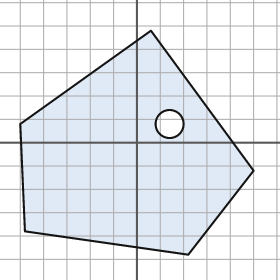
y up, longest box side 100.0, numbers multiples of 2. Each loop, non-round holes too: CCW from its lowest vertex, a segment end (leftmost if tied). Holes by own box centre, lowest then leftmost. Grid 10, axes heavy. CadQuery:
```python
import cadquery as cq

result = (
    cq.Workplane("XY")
    .moveTo(22.0, -48.0)
    .lineTo(50.0, -12.0)
    .lineTo(6.0, 48.0)
    .lineTo(-50.0, 8.0)
    .lineTo(-48.0, -38.0)
    .close()
    .moveTo(14.0, 8.0)
    .circle(6.0)
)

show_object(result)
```